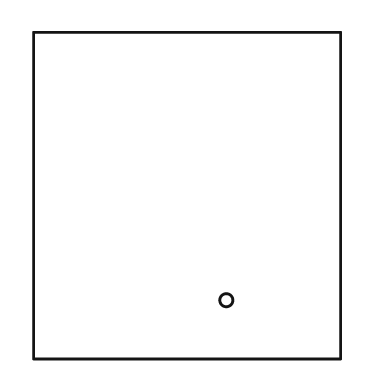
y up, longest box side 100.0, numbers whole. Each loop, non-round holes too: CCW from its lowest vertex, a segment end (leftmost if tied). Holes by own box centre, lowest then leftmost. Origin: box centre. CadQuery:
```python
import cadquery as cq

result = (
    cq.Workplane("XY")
    .moveTo(-47.0, -50.0)
    .lineTo(47.0, -50.0)
    .lineTo(47.0, 50.0)
    .lineTo(-47.0, 50.0)
    .close()
    .moveTo(12.0, -32.0)
    .circle(2.0)
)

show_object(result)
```